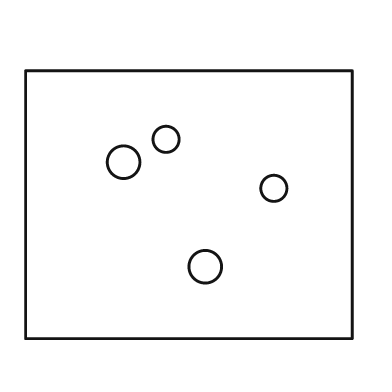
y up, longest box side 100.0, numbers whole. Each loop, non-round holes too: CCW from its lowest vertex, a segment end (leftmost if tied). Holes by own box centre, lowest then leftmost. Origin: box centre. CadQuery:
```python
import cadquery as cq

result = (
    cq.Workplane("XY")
    .moveTo(-50.0, -41.0)
    .lineTo(50.0, -41.0)
    .lineTo(50.0, 41.0)
    .lineTo(-50.0, 41.0)
    .close()
    .moveTo(5.0, -19.0)
    .circle(5.0)
    .moveTo(26.0, 5.0)
    .circle(4.0)
    .moveTo(-20.0, 13.0)
    .circle(5.0)
    .moveTo(-7.0, 20.0)
    .circle(4.0)
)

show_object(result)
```